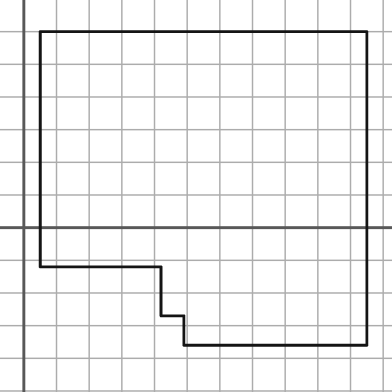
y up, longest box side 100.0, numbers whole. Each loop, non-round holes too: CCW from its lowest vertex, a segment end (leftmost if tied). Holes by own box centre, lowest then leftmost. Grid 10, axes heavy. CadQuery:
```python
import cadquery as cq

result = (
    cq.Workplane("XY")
    .moveTo(49.0, -36.0)
    .lineTo(105.0, -36.0)
    .lineTo(105.0, 60.0)
    .lineTo(5.0, 60.0)
    .lineTo(5.0, -12.0)
    .lineTo(42.0, -12.0)
    .lineTo(42.0, -27.0)
    .lineTo(49.0, -27.0)
    .close()
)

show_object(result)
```